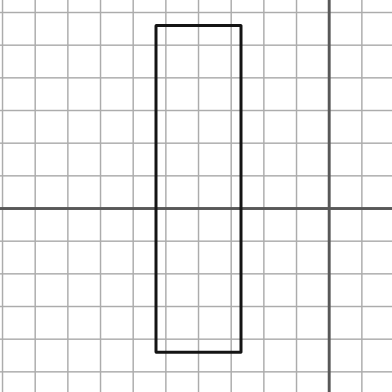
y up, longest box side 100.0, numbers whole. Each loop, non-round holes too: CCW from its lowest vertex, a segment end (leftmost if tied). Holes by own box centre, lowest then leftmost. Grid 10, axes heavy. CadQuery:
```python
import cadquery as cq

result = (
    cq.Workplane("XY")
    .moveTo(-53.0, -44.0)
    .lineTo(-27.0, -44.0)
    .lineTo(-27.0, 56.0)
    .lineTo(-53.0, 56.0)
    .close()
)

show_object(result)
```